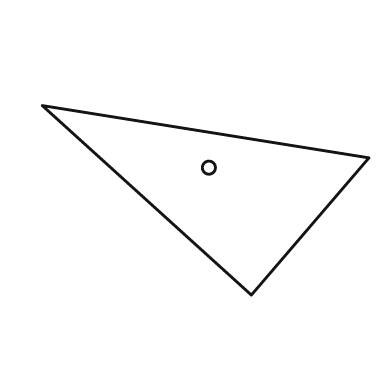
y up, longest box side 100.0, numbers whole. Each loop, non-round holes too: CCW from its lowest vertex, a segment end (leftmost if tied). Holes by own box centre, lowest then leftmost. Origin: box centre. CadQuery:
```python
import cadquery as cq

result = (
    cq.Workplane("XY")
    .moveTo(14.0, -29.0)
    .lineTo(50.0, 13.0)
    .lineTo(-50.0, 29.0)
    .close()
    .moveTo(1.0, 10.0)
    .circle(2.0)
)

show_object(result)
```